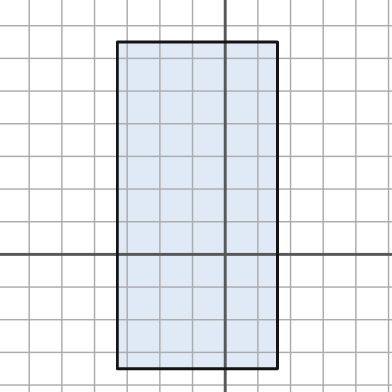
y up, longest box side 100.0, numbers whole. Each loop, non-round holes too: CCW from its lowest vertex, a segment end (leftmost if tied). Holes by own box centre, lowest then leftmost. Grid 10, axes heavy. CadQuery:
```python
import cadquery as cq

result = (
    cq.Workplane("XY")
    .moveTo(-33.0, -35.0)
    .lineTo(16.0, -35.0)
    .lineTo(16.0, 65.0)
    .lineTo(-33.0, 65.0)
    .close()
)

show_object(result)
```